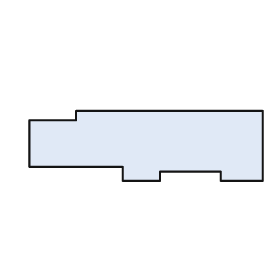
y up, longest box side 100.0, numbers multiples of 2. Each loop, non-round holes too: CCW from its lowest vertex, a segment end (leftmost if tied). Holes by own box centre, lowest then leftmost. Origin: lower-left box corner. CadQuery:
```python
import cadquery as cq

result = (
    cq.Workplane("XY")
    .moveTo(40.0, 0.0)
    .lineTo(56.0, 0.0)
    .lineTo(56.0, 4.0)
    .lineTo(82.0, 4.0)
    .lineTo(82.0, 0.0)
    .lineTo(100.0, 0.0)
    .lineTo(100.0, 30.0)
    .lineTo(20.0, 30.0)
    .lineTo(20.0, 26.0)
    .lineTo(0.0, 26.0)
    .lineTo(0.0, 6.0)
    .lineTo(40.0, 6.0)
    .close()
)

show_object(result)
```